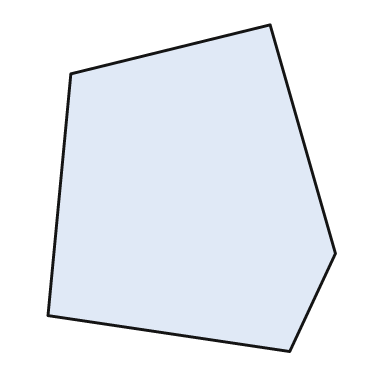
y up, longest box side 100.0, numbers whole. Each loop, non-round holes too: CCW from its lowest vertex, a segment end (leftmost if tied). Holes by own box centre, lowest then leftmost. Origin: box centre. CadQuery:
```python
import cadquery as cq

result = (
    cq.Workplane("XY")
    .moveTo(30.0, -50.0)
    .lineTo(44.0, -20.0)
    .lineTo(24.0, 50.0)
    .lineTo(-37.0, 35.0)
    .lineTo(-44.0, -39.0)
    .close()
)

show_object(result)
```